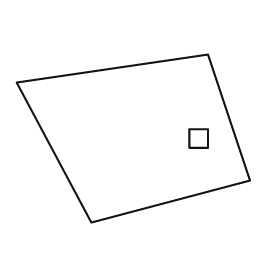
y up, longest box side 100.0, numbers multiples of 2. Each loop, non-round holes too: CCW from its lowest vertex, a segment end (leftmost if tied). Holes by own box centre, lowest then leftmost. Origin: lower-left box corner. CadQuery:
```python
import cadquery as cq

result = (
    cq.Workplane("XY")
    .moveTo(32.0, 0.0)
    .lineTo(100.0, 18.0)
    .lineTo(82.0, 72.0)
    .lineTo(0.0, 60.0)
    .close()
    .moveTo(74.0, 32.0)
    .lineTo(82.0, 32.0)
    .lineTo(82.0, 40.0)
    .lineTo(74.0, 40.0)
    .close()
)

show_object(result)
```